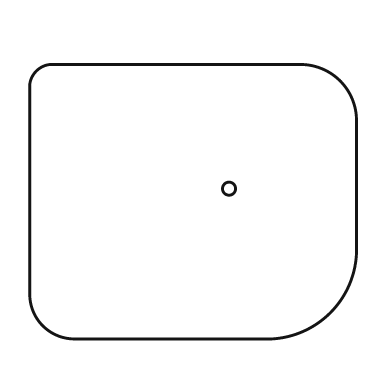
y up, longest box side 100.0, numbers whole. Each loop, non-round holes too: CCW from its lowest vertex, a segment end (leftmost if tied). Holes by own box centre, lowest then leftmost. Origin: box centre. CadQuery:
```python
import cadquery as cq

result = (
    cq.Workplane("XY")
    .moveTo(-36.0, -42.0)
    .lineTo(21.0, -42.0)
    .threePointArc((42.0, -34.0), (50.0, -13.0))
    .lineTo(50.0, 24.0)
    .threePointArc((45.0, 37.0), (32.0, 42.0))
    .lineTo(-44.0, 42.0)
    .threePointArc((-48.0, 40.0), (-50.0, 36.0))
    .lineTo(-50.0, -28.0)
    .threePointArc((-46.0, -38.0), (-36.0, -42.0))
    .close()
    .moveTo(11.0, 4.0)
    .circle(2.0)
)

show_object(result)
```